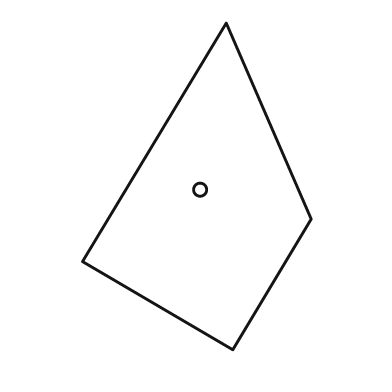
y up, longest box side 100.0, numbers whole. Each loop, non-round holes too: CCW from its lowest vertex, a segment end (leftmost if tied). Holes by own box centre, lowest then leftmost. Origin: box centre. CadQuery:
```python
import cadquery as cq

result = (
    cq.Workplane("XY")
    .moveTo(11.0, -50.0)
    .lineTo(35.0, -10.0)
    .lineTo(9.0, 50.0)
    .lineTo(-35.0, -23.0)
    .close()
    .moveTo(1.0, -1.0)
    .circle(2.0)
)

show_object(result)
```